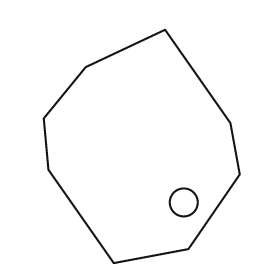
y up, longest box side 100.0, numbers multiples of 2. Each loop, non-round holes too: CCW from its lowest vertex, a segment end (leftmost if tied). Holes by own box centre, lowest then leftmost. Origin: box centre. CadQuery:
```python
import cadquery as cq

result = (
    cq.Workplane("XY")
    .moveTo(-12.0, -50.0)
    .lineTo(20.0, -44.0)
    .lineTo(42.0, -12.0)
    .lineTo(38.0, 10.0)
    .lineTo(10.0, 50.0)
    .lineTo(-24.0, 34.0)
    .lineTo(-42.0, 12.0)
    .lineTo(-40.0, -10.0)
    .close()
    .moveTo(18.0, -24.0)
    .circle(6.0)
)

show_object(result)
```